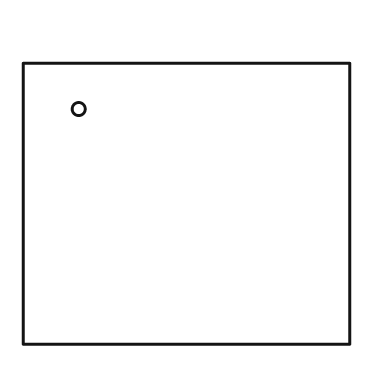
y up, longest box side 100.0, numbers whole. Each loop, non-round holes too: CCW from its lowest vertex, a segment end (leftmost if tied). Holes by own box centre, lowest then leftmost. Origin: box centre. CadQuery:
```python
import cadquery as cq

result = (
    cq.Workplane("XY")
    .moveTo(-50.0, -43.0)
    .lineTo(50.0, -43.0)
    .lineTo(50.0, 43.0)
    .lineTo(-50.0, 43.0)
    .close()
    .moveTo(-33.0, 29.0)
    .circle(2.0)
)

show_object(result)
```